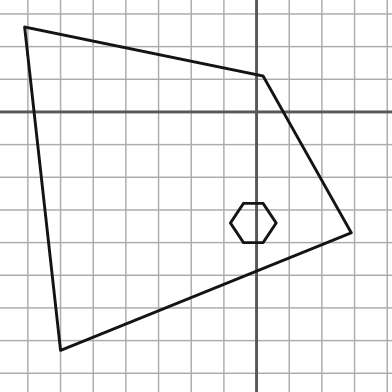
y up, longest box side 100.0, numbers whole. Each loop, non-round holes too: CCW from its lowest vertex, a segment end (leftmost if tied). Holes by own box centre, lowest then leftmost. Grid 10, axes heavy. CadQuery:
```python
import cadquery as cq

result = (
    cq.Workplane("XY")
    .moveTo(-60.0, -73.0)
    .lineTo(29.0, -37.0)
    .lineTo(2.0, 11.0)
    .lineTo(-71.0, 26.0)
    .close()
    .moveTo(-4.0, -40.0)
    .lineTo(2.0, -40.0)
    .lineTo(6.0, -34.0)
    .lineTo(2.0, -28.0)
    .lineTo(-4.0, -28.0)
    .lineTo(-8.0, -34.0)
    .close()
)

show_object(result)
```